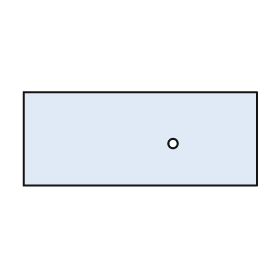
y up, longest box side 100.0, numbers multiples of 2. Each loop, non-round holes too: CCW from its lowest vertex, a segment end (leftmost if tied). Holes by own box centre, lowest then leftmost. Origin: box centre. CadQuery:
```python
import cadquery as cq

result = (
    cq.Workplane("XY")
    .moveTo(-50.0, -20.0)
    .lineTo(50.0, -20.0)
    .lineTo(50.0, 20.0)
    .lineTo(-50.0, 20.0)
    .close()
    .moveTo(14.0, -2.0)
    .circle(2.0)
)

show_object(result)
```